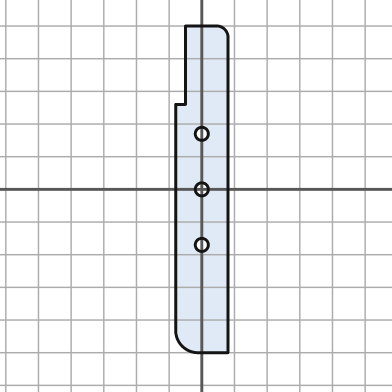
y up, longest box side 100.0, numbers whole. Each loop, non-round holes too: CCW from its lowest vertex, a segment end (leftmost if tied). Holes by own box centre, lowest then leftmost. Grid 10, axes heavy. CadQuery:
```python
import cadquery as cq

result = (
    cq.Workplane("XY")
    .moveTo(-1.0, -50.0)
    .lineTo(8.0, -50.0)
    .lineTo(8.0, 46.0)
    .threePointArc((7.0, 49.0), (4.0, 50.0))
    .lineTo(-5.0, 50.0)
    .lineTo(-5.0, 26.0)
    .lineTo(-8.0, 26.0)
    .lineTo(-8.0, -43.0)
    .threePointArc((-6.0, -48.0), (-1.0, -50.0))
    .close()
    .moveTo(0.0, -17.0)
    .circle(2.0)
    .moveTo(0.0, 0.0)
    .circle(2.0)
    .moveTo(0.0, 17.0)
    .circle(2.0)
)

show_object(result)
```